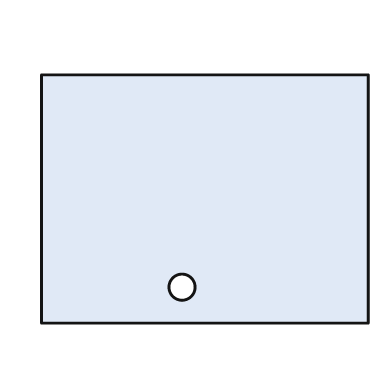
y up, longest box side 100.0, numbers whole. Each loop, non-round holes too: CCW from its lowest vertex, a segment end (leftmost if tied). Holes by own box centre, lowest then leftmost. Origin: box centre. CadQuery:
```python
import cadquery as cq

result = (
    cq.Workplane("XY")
    .moveTo(-50.0, -38.0)
    .lineTo(50.0, -38.0)
    .lineTo(50.0, 38.0)
    .lineTo(-50.0, 38.0)
    .close()
    .moveTo(-7.0, -27.0)
    .circle(4.0)
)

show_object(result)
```